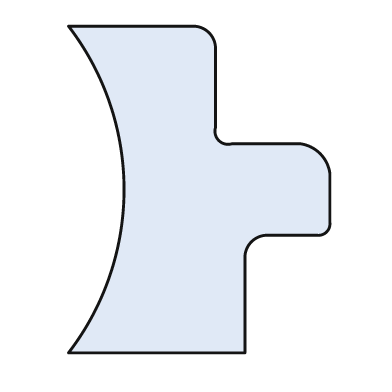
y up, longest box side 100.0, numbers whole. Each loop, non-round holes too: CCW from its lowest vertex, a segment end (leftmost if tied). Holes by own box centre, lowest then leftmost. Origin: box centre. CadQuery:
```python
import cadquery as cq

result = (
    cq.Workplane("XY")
    .moveTo(-40.0, -50.0)
    .lineTo(14.0, -50.0)
    .lineTo(14.0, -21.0)
    .threePointArc((16.0, -16.0), (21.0, -14.0))
    .lineTo(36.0, -14.0)
    .threePointArc((39.0, -13.0), (40.0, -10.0))
    .lineTo(40.0, 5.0)
    .threePointArc((37.0, 11.0), (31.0, 14.0))
    .lineTo(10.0, 14.0)
    .threePointArc((6.0, 15.0), (5.0, 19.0))
    .lineTo(5.0, 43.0)
    .threePointArc((3.0, 48.0), (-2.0, 50.0))
    .lineTo(-40.0, 50.0)
    .threePointArc((-23.0, 0.0), (-40.0, -50.0))
    .close()
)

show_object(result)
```